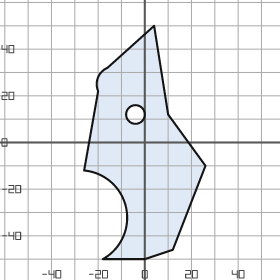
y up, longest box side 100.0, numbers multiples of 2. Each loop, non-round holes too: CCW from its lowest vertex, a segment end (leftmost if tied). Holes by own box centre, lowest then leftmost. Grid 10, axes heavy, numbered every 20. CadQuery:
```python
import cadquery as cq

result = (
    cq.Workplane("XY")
    .moveTo(-18.0, -50.0)
    .lineTo(0.0, -50.0)
    .lineTo(12.0, -46.0)
    .lineTo(26.0, -10.0)
    .lineTo(10.0, 12.0)
    .lineTo(4.0, 50.0)
    .lineTo(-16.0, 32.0)
    .threePointArc((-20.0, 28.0), (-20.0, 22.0))
    .lineTo(-26.0, -12.0)
    .threePointArc((-8.0, -28.0), (-18.0, -50.0))
    .close()
    .moveTo(-4.0, 12.0)
    .circle(4.0)
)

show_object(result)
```